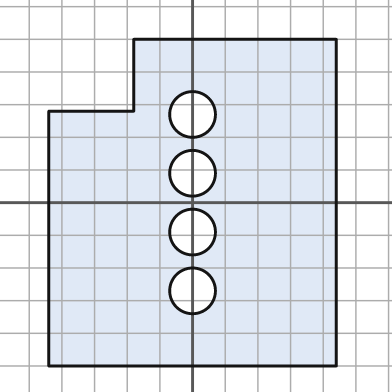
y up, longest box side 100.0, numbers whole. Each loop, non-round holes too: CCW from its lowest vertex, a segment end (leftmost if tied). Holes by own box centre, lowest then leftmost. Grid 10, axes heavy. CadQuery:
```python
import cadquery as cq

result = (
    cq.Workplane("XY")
    .moveTo(-44.0, -50.0)
    .lineTo(44.0, -50.0)
    .lineTo(44.0, 50.0)
    .lineTo(-18.0, 50.0)
    .lineTo(-18.0, 28.0)
    .lineTo(-44.0, 28.0)
    .close()
    .moveTo(0.0, -27.0)
    .circle(7.0)
    .moveTo(0.0, -9.0)
    .circle(7.0)
    .moveTo(0.0, 9.0)
    .circle(7.0)
    .moveTo(0.0, 27.0)
    .circle(7.0)
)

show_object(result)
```